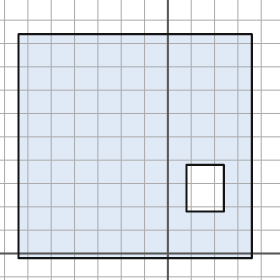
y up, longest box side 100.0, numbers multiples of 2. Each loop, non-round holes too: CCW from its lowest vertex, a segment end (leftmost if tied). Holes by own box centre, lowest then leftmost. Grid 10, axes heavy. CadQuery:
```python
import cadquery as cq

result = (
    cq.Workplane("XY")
    .moveTo(-64.0, -2.0)
    .lineTo(36.0, -2.0)
    .lineTo(36.0, 94.0)
    .lineTo(-64.0, 94.0)
    .close()
    .moveTo(8.0, 18.0)
    .lineTo(24.0, 18.0)
    .lineTo(24.0, 38.0)
    .lineTo(8.0, 38.0)
    .close()
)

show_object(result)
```